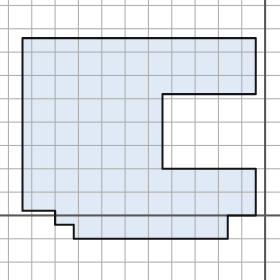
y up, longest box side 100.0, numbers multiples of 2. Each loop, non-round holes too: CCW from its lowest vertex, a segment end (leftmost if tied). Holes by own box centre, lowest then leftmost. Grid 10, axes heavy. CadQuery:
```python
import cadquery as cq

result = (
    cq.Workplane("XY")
    .moveTo(-82.0, -10.0)
    .lineTo(-16.0, -10.0)
    .lineTo(-16.0, 0.0)
    .lineTo(-4.0, 0.0)
    .lineTo(-4.0, 20.0)
    .lineTo(-44.0, 20.0)
    .lineTo(-44.0, 52.0)
    .lineTo(-4.0, 52.0)
    .lineTo(-4.0, 76.0)
    .lineTo(-104.0, 76.0)
    .lineTo(-104.0, 2.0)
    .lineTo(-90.0, 2.0)
    .lineTo(-90.0, -4.0)
    .lineTo(-82.0, -4.0)
    .close()
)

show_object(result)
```